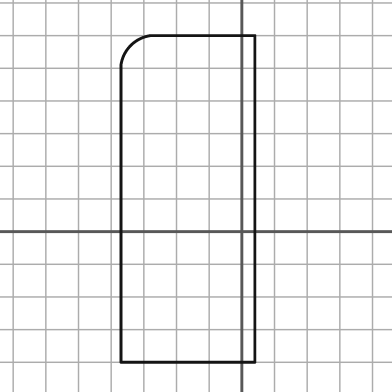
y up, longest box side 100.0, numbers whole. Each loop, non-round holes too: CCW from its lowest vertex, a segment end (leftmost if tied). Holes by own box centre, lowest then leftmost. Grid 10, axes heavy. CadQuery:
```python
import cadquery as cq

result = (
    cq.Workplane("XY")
    .moveTo(-37.0, -40.0)
    .lineTo(4.0, -40.0)
    .lineTo(4.0, 60.0)
    .lineTo(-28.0, 60.0)
    .threePointArc((-34.0, 57.0), (-37.0, 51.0))
    .close()
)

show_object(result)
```